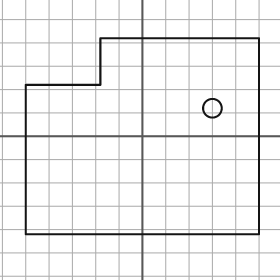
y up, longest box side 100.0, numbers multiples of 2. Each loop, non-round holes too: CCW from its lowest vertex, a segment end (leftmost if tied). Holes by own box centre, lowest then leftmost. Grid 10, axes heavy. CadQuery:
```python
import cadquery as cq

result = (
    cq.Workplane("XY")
    .moveTo(-50.0, -42.0)
    .lineTo(50.0, -42.0)
    .lineTo(50.0, 42.0)
    .lineTo(-18.0, 42.0)
    .lineTo(-18.0, 22.0)
    .lineTo(-50.0, 22.0)
    .close()
    .moveTo(30.0, 12.0)
    .circle(4.0)
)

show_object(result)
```